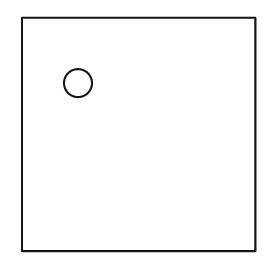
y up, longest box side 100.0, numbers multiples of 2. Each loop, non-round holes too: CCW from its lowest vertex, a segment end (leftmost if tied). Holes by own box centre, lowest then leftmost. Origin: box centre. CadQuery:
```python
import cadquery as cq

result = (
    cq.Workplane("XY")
    .moveTo(-50.0, -50.0)
    .lineTo(50.0, -50.0)
    .lineTo(50.0, 50.0)
    .lineTo(-50.0, 50.0)
    .close()
    .moveTo(-26.0, 22.0)
    .circle(6.0)
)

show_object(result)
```